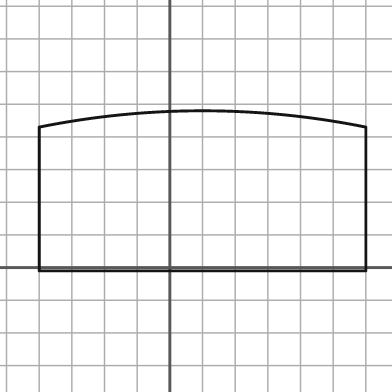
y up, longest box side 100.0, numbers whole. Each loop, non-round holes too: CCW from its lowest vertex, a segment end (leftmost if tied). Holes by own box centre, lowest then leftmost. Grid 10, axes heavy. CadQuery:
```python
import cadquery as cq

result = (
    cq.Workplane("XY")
    .moveTo(-40.0, -1.0)
    .lineTo(60.0, -1.0)
    .lineTo(60.0, 43.0)
    .threePointArc((10.0, 48.0), (-40.0, 43.0))
    .close()
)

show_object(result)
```